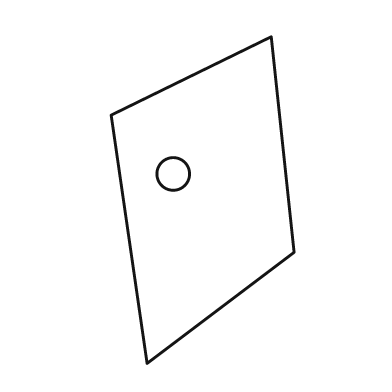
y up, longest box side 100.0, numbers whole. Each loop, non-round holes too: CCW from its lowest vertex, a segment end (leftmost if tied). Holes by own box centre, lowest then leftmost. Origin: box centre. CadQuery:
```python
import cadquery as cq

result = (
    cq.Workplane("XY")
    .moveTo(-17.0, -50.0)
    .lineTo(28.0, -16.0)
    .lineTo(21.0, 50.0)
    .lineTo(-28.0, 26.0)
    .close()
    .moveTo(-9.0, 8.0)
    .circle(5.0)
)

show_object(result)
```